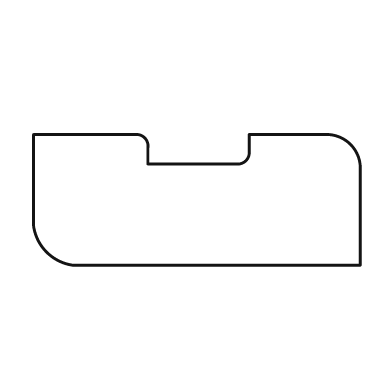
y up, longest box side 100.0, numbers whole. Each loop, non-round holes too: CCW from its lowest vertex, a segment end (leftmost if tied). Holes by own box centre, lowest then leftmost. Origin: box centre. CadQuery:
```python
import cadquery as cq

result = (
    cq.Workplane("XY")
    .moveTo(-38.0, -20.0)
    .lineTo(50.0, -20.0)
    .lineTo(50.0, 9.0)
    .threePointArc((47.0, 17.0), (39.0, 20.0))
    .lineTo(16.0, 20.0)
    .lineTo(16.0, 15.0)
    .threePointArc((15.0, 12.0), (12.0, 11.0))
    .lineTo(-15.0, 11.0)
    .lineTo(-15.0, 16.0)
    .threePointArc((-16.0, 19.0), (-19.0, 20.0))
    .lineTo(-50.0, 20.0)
    .lineTo(-50.0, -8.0)
    .threePointArc((-46.0, -16.0), (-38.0, -20.0))
    .close()
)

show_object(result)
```